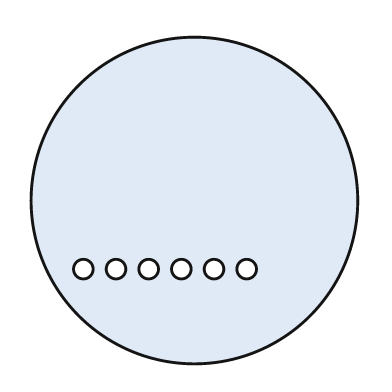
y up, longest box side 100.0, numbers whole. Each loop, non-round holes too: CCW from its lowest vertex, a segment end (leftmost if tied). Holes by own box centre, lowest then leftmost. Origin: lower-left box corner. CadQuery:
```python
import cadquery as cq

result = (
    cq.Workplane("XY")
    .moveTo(50.0, 50.0)
    .circle(50.0)
    .moveTo(16.0, 29.0)
    .circle(3.0)
    .moveTo(26.0, 29.0)
    .circle(3.0)
    .moveTo(36.0, 29.0)
    .circle(3.0)
    .moveTo(46.0, 29.0)
    .circle(3.0)
    .moveTo(56.0, 29.0)
    .circle(3.0)
    .moveTo(66.0, 29.0)
    .circle(3.0)
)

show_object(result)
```